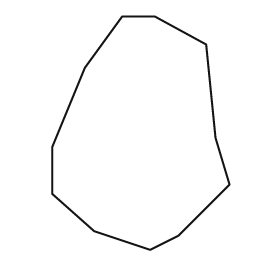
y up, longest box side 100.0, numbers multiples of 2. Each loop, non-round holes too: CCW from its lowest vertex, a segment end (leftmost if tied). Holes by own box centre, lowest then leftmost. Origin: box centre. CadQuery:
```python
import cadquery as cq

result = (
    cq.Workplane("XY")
    .moveTo(4.0, -50.0)
    .lineTo(16.0, -44.0)
    .lineTo(38.0, -22.0)
    .lineTo(32.0, -2.0)
    .lineTo(28.0, 38.0)
    .lineTo(6.0, 50.0)
    .lineTo(-8.0, 50.0)
    .lineTo(-24.0, 28.0)
    .lineTo(-38.0, -6.0)
    .lineTo(-38.0, -26.0)
    .lineTo(-20.0, -42.0)
    .close()
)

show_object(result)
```